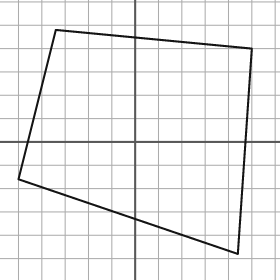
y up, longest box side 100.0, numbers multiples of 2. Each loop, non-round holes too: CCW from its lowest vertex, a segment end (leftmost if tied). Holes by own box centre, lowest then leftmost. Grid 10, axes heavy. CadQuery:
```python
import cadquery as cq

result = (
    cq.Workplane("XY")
    .moveTo(44.0, -48.0)
    .lineTo(50.0, 40.0)
    .lineTo(-34.0, 48.0)
    .lineTo(-50.0, -16.0)
    .close()
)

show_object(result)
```